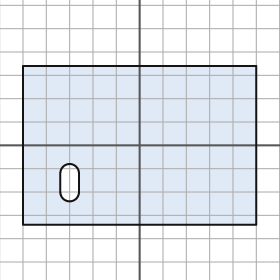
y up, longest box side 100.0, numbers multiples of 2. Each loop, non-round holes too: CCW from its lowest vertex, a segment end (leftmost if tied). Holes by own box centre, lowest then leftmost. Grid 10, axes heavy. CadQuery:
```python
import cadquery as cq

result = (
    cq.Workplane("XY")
    .moveTo(-50.0, -34.0)
    .lineTo(50.0, -34.0)
    .lineTo(50.0, 34.0)
    .lineTo(-50.0, 34.0)
    .close()
    .moveTo(-34.0, -20.0)
    .threePointArc((-30.0, -24.0), (-26.0, -20.0))
    .lineTo(-26.0, -12.0)
    .threePointArc((-30.0, -8.0), (-34.0, -12.0))
    .close()
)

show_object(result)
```